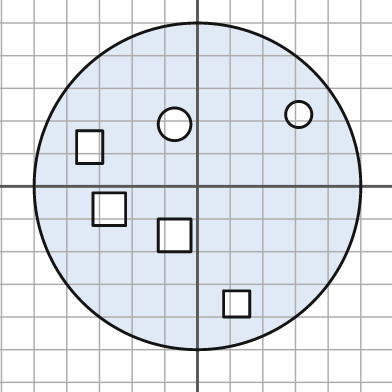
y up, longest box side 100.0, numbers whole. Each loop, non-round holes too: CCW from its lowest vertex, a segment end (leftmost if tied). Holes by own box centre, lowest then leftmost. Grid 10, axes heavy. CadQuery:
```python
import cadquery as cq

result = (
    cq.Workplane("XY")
    .moveTo(0.0, 0.0)
    .circle(50.0)
    .moveTo(8.0, -40.0)
    .lineTo(16.0, -40.0)
    .lineTo(16.0, -32.0)
    .lineTo(8.0, -32.0)
    .close()
    .moveTo(-12.0, -20.0)
    .lineTo(-2.0, -20.0)
    .lineTo(-2.0, -10.0)
    .lineTo(-12.0, -10.0)
    .close()
    .moveTo(-32.0, -12.0)
    .lineTo(-22.0, -12.0)
    .lineTo(-22.0, -2.0)
    .lineTo(-32.0, -2.0)
    .close()
    .moveTo(-37.0, 7.0)
    .lineTo(-29.0, 7.0)
    .lineTo(-29.0, 17.0)
    .lineTo(-37.0, 17.0)
    .close()
    .moveTo(-7.0, 19.0)
    .circle(5.0)
    .moveTo(31.0, 22.0)
    .circle(4.0)
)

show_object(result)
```